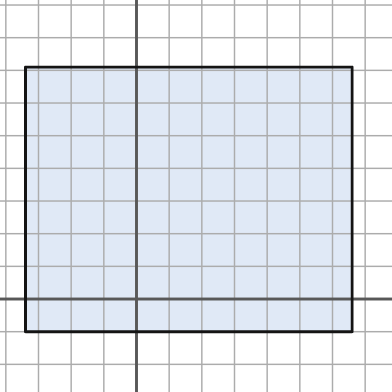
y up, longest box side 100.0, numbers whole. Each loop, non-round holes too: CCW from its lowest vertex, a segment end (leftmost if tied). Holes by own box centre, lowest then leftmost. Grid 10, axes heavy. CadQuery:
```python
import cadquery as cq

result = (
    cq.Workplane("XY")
    .moveTo(-34.0, -10.0)
    .lineTo(66.0, -10.0)
    .lineTo(66.0, 71.0)
    .lineTo(-34.0, 71.0)
    .close()
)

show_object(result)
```